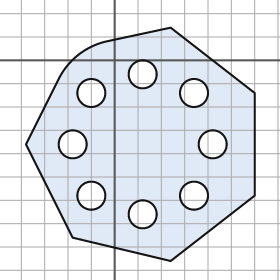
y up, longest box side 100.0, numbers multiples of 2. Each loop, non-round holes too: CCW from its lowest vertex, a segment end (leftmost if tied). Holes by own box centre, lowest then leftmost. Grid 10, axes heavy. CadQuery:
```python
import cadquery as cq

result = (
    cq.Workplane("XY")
    .moveTo(24.0, -86.0)
    .lineTo(60.0, -58.0)
    .lineTo(60.0, -14.0)
    .lineTo(24.0, 14.0)
    .lineTo(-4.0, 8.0)
    .threePointArc((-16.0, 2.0), (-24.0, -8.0))
    .lineTo(-38.0, -36.0)
    .lineTo(-18.0, -76.0)
    .close()
    .moveTo(12.0, -66.0)
    .circle(6.0)
    .moveTo(-10.0, -58.0)
    .circle(6.0)
    .moveTo(34.0, -58.0)
    .circle(6.0)
    .moveTo(-18.0, -36.0)
    .circle(6.0)
    .moveTo(42.0, -36.0)
    .circle(6.0)
    .moveTo(-10.0, -14.0)
    .circle(6.0)
    .moveTo(34.0, -14.0)
    .circle(6.0)
    .moveTo(12.0, -6.0)
    .circle(6.0)
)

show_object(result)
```